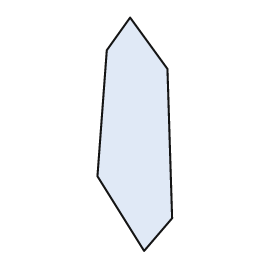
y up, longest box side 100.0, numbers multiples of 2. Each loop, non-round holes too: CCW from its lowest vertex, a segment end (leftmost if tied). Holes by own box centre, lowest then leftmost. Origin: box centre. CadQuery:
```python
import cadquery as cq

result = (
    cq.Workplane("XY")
    .moveTo(4.0, -50.0)
    .lineTo(16.0, -36.0)
    .lineTo(14.0, 28.0)
    .lineTo(-2.0, 50.0)
    .lineTo(-12.0, 36.0)
    .lineTo(-16.0, -18.0)
    .close()
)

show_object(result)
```